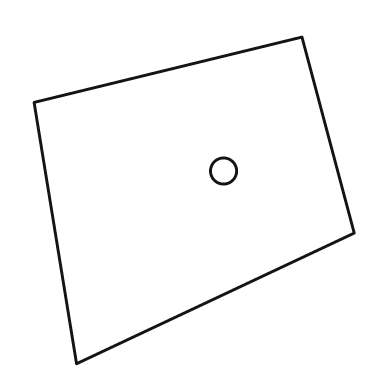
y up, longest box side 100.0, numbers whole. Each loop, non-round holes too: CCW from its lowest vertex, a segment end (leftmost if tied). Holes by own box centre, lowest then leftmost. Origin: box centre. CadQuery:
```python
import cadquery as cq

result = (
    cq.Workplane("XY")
    .moveTo(-36.0, -50.0)
    .lineTo(49.0, -10.0)
    .lineTo(33.0, 50.0)
    .lineTo(-49.0, 30.0)
    .close()
    .moveTo(9.0, 9.0)
    .circle(4.0)
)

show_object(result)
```